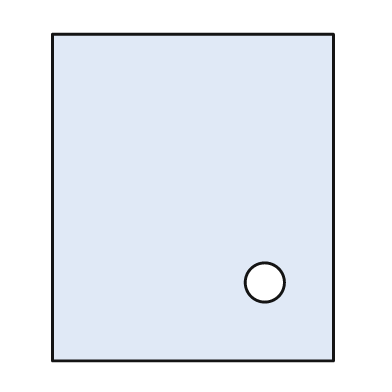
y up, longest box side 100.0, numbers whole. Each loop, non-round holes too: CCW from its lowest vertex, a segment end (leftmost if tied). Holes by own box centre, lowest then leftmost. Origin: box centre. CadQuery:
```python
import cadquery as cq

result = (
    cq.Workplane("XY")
    .moveTo(-43.0, -50.0)
    .lineTo(43.0, -50.0)
    .lineTo(43.0, 50.0)
    .lineTo(-43.0, 50.0)
    .close()
    .moveTo(22.0, -26.0)
    .circle(6.0)
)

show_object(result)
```